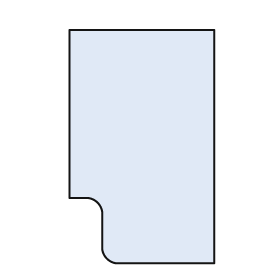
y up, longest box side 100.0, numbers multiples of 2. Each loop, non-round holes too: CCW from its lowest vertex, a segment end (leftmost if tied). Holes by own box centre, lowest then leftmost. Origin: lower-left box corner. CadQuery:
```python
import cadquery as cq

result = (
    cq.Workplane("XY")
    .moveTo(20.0, 0.0)
    .lineTo(62.0, 0.0)
    .lineTo(62.0, 100.0)
    .lineTo(0.0, 100.0)
    .lineTo(0.0, 28.0)
    .lineTo(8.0, 28.0)
    .threePointArc((12.0, 26.0), (14.0, 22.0))
    .lineTo(14.0, 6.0)
    .threePointArc((16.0, 2.0), (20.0, 0.0))
    .close()
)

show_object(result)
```